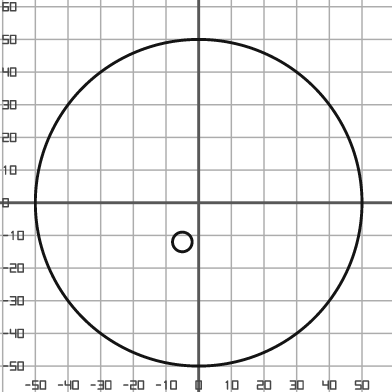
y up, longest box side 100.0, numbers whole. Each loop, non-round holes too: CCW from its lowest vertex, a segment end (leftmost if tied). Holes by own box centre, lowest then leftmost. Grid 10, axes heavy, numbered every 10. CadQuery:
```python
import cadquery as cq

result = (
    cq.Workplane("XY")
    .moveTo(0.0, 0.0)
    .circle(50.0)
    .moveTo(-5.0, -12.0)
    .circle(3.0)
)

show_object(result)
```